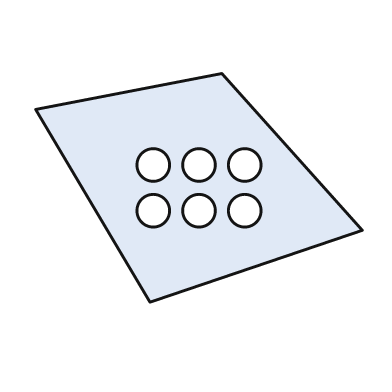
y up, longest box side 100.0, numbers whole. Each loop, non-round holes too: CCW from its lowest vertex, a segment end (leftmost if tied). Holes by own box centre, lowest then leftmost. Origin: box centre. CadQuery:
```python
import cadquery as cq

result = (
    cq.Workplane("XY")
    .moveTo(-15.0, -35.0)
    .lineTo(50.0, -13.0)
    .lineTo(7.0, 35.0)
    .lineTo(-50.0, 24.0)
    .close()
    .moveTo(-14.0, -7.0)
    .circle(5.0)
    .moveTo(0.0, -7.0)
    .circle(5.0)
    .moveTo(14.0, -7.0)
    .circle(5.0)
    .moveTo(-14.0, 7.0)
    .circle(5.0)
    .moveTo(0.0, 7.0)
    .circle(5.0)
    .moveTo(14.0, 7.0)
    .circle(5.0)
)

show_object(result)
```